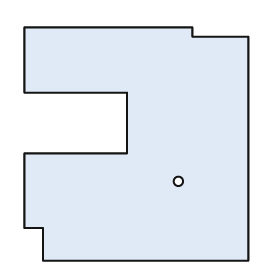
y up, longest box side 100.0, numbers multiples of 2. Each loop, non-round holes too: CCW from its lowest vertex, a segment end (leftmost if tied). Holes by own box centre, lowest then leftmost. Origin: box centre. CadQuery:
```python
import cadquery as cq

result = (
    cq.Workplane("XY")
    .moveTo(-40.0, -50.0)
    .lineTo(48.0, -50.0)
    .lineTo(48.0, 46.0)
    .lineTo(24.0, 46.0)
    .lineTo(24.0, 50.0)
    .lineTo(-48.0, 50.0)
    .lineTo(-48.0, 22.0)
    .lineTo(-4.0, 22.0)
    .lineTo(-4.0, -4.0)
    .lineTo(-48.0, -4.0)
    .lineTo(-48.0, -36.0)
    .lineTo(-40.0, -36.0)
    .close()
    .moveTo(18.0, -16.0)
    .circle(2.0)
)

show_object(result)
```